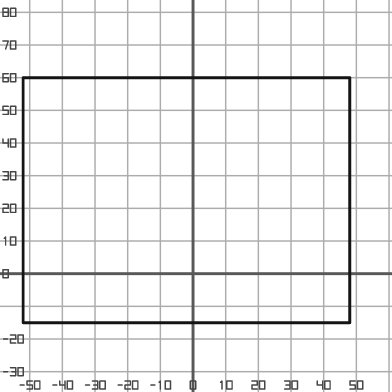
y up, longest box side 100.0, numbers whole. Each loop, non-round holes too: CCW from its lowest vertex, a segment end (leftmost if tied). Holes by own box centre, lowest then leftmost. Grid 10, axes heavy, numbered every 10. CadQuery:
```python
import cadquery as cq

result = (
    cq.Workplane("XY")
    .moveTo(-52.0, -15.0)
    .lineTo(48.0, -15.0)
    .lineTo(48.0, 60.0)
    .lineTo(-52.0, 60.0)
    .close()
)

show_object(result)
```